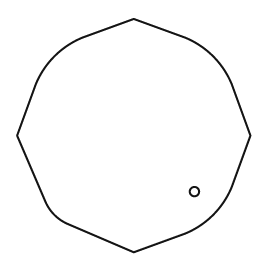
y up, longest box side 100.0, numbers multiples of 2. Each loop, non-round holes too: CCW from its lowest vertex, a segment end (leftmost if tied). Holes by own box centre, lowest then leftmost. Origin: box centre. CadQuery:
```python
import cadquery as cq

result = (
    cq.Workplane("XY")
    .moveTo(0.0, -50.0)
    .lineTo(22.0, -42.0)
    .threePointArc((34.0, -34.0), (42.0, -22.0))
    .lineTo(50.0, 0.0)
    .lineTo(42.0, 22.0)
    .threePointArc((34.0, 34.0), (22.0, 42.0))
    .lineTo(0.0, 50.0)
    .lineTo(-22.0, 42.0)
    .threePointArc((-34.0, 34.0), (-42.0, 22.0))
    .lineTo(-50.0, 0.0)
    .lineTo(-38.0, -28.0)
    .threePointArc((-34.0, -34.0), (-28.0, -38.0))
    .close()
    .moveTo(26.0, -24.0)
    .circle(2.0)
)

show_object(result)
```